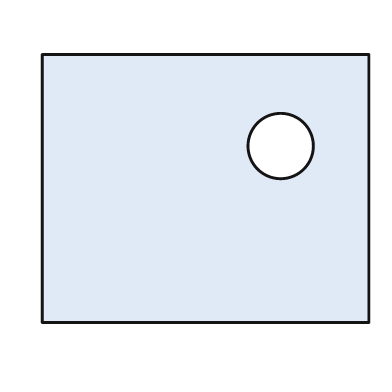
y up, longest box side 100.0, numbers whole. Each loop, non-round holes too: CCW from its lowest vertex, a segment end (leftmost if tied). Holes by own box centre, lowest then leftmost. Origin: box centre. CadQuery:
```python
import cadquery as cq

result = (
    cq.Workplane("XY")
    .moveTo(-50.0, -41.0)
    .lineTo(50.0, -41.0)
    .lineTo(50.0, 41.0)
    .lineTo(-50.0, 41.0)
    .close()
    .moveTo(23.0, 13.0)
    .circle(10.0)
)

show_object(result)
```